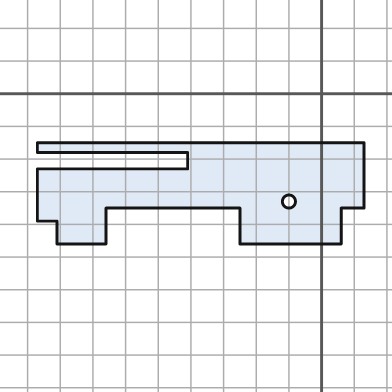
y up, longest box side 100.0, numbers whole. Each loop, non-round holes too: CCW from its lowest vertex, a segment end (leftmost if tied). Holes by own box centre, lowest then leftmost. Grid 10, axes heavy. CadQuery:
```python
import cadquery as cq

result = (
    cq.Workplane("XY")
    .moveTo(-81.0, -46.0)
    .lineTo(-66.0, -46.0)
    .lineTo(-66.0, -35.0)
    .lineTo(-25.0, -35.0)
    .lineTo(-25.0, -46.0)
    .lineTo(6.0, -46.0)
    .lineTo(6.0, -35.0)
    .lineTo(13.0, -35.0)
    .lineTo(13.0, -15.0)
    .lineTo(-87.0, -15.0)
    .lineTo(-87.0, -18.0)
    .lineTo(-41.0, -18.0)
    .lineTo(-41.0, -23.0)
    .lineTo(-87.0, -23.0)
    .lineTo(-87.0, -39.0)
    .lineTo(-81.0, -39.0)
    .close()
    .moveTo(-10.0, -33.0)
    .circle(2.0)
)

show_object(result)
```